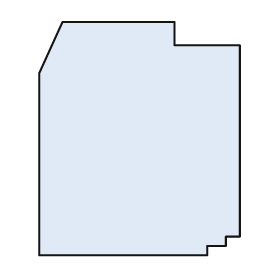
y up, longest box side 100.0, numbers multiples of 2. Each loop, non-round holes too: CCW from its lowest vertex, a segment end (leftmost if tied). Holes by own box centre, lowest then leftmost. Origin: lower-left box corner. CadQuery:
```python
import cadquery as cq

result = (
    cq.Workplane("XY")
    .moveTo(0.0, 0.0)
    .lineTo(72.0, 0.0)
    .lineTo(72.0, 4.0)
    .lineTo(80.0, 4.0)
    .lineTo(80.0, 8.0)
    .lineTo(86.0, 8.0)
    .lineTo(86.0, 90.0)
    .lineTo(58.0, 90.0)
    .lineTo(58.0, 100.0)
    .lineTo(10.0, 100.0)
    .lineTo(0.0, 78.0)
    .close()
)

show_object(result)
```